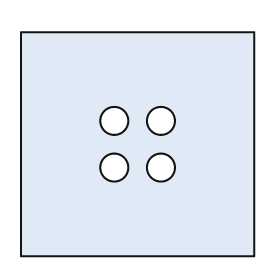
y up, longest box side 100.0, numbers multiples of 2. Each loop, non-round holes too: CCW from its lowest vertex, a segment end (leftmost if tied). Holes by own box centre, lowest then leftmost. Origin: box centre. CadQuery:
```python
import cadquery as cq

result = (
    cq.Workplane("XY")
    .moveTo(-50.0, -48.0)
    .lineTo(50.0, -48.0)
    .lineTo(50.0, 48.0)
    .lineTo(-50.0, 48.0)
    .close()
    .moveTo(-10.0, -10.0)
    .circle(6.0)
    .moveTo(10.0, -10.0)
    .circle(6.0)
    .moveTo(-10.0, 10.0)
    .circle(6.0)
    .moveTo(10.0, 10.0)
    .circle(6.0)
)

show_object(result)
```